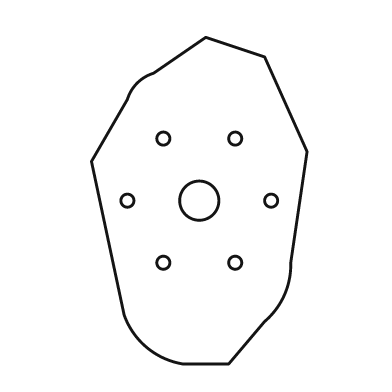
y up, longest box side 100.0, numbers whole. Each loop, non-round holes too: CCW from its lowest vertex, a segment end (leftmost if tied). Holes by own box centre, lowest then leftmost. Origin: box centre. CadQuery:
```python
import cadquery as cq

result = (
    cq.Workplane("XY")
    .moveTo(-5.0, -50.0)
    .lineTo(9.0, -50.0)
    .lineTo(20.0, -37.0)
    .threePointArc((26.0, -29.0), (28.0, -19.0))
    .lineTo(33.0, 15.0)
    .lineTo(20.0, 44.0)
    .lineTo(2.0, 50.0)
    .lineTo(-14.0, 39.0)
    .threePointArc((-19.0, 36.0), (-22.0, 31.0))
    .lineTo(-33.0, 12.0)
    .lineTo(-23.0, -35.0)
    .threePointArc((-16.0, -45.0), (-5.0, -50.0))
    .close()
    .moveTo(-11.0, -19.0)
    .circle(2.0)
    .moveTo(11.0, -19.0)
    .circle(2.0)
    .moveTo(-22.0, 0.0)
    .circle(2.0)
    .moveTo(0.0, 0.0)
    .circle(6.0)
    .moveTo(22.0, 0.0)
    .circle(2.0)
    .moveTo(-11.0, 19.0)
    .circle(2.0)
    .moveTo(11.0, 19.0)
    .circle(2.0)
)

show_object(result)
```